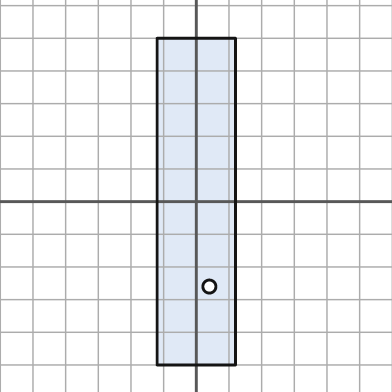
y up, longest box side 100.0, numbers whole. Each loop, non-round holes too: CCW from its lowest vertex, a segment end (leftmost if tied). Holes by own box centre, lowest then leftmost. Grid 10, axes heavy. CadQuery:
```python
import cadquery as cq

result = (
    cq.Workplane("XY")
    .moveTo(-12.0, -50.0)
    .lineTo(12.0, -50.0)
    .lineTo(12.0, 50.0)
    .lineTo(-12.0, 50.0)
    .close()
    .moveTo(4.0, -26.0)
    .circle(2.0)
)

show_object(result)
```